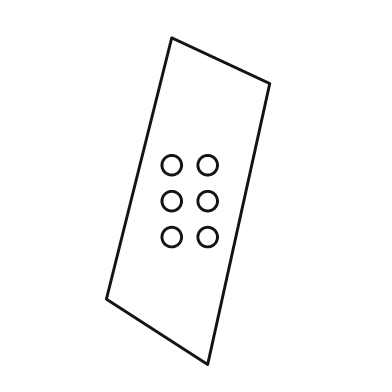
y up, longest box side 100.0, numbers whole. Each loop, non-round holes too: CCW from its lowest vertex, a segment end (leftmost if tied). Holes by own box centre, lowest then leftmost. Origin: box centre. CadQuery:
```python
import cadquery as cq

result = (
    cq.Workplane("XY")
    .moveTo(6.0, -50.0)
    .lineTo(25.0, 36.0)
    .lineTo(-5.0, 50.0)
    .lineTo(-25.0, -30.0)
    .close()
    .moveTo(-5.0, -11.0)
    .circle(3.0)
    .moveTo(6.0, -11.0)
    .circle(3.0)
    .moveTo(-5.0, 0.0)
    .circle(3.0)
    .moveTo(6.0, 0.0)
    .circle(3.0)
    .moveTo(-5.0, 11.0)
    .circle(3.0)
    .moveTo(6.0, 11.0)
    .circle(3.0)
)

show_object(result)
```